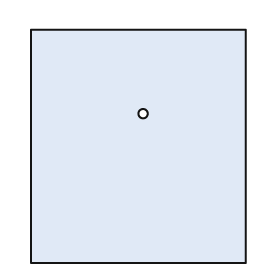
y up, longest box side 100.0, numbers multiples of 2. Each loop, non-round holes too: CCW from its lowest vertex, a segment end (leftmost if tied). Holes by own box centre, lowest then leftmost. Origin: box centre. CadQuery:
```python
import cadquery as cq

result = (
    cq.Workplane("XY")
    .moveTo(-46.0, -50.0)
    .lineTo(46.0, -50.0)
    .lineTo(46.0, 50.0)
    .lineTo(-46.0, 50.0)
    .close()
    .moveTo(2.0, 14.0)
    .circle(2.0)
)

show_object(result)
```